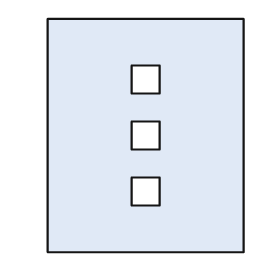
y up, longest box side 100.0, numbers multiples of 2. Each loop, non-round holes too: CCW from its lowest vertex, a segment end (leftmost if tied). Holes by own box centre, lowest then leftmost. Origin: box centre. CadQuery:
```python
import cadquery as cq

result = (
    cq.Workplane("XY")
    .moveTo(-42.0, -50.0)
    .lineTo(42.0, -50.0)
    .lineTo(42.0, 50.0)
    .lineTo(-42.0, 50.0)
    .close()
    .moveTo(-6.0, -30.0)
    .lineTo(6.0, -30.0)
    .lineTo(6.0, -18.0)
    .lineTo(-6.0, -18.0)
    .close()
    .moveTo(-6.0, -6.0)
    .lineTo(6.0, -6.0)
    .lineTo(6.0, 6.0)
    .lineTo(-6.0, 6.0)
    .close()
    .moveTo(-6.0, 18.0)
    .lineTo(6.0, 18.0)
    .lineTo(6.0, 30.0)
    .lineTo(-6.0, 30.0)
    .close()
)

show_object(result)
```